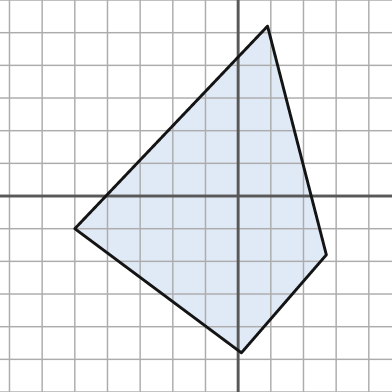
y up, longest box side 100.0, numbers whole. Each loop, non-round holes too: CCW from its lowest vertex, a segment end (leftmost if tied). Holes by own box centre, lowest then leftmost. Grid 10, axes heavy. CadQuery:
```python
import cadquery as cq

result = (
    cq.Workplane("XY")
    .moveTo(1.0, -48.0)
    .lineTo(27.0, -18.0)
    .lineTo(9.0, 52.0)
    .lineTo(-50.0, -10.0)
    .close()
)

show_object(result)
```